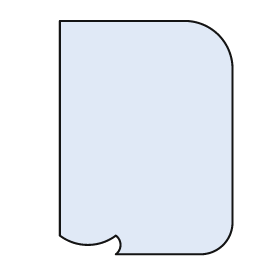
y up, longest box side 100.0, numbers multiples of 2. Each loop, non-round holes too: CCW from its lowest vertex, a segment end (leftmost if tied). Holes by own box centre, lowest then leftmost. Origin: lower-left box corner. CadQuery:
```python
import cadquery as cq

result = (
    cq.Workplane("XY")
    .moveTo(24.0, 0.0)
    .lineTo(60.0, 0.0)
    .threePointArc((70.0, 4.0), (74.0, 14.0))
    .lineTo(74.0, 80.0)
    .threePointArc((68.0, 94.0), (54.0, 100.0))
    .lineTo(0.0, 100.0)
    .lineTo(0.0, 8.0)
    .threePointArc((12.0, 4.0), (24.0, 8.0))
    .threePointArc((26.0, 4.0), (24.0, 0.0))
    .close()
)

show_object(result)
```